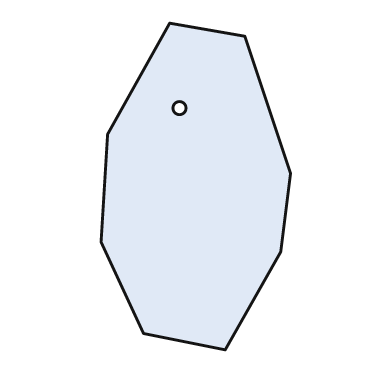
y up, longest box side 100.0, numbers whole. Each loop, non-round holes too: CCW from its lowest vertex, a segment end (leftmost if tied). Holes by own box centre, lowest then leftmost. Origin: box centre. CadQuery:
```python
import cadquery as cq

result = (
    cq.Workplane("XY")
    .moveTo(9.0, -50.0)
    .lineTo(26.0, -20.0)
    .lineTo(29.0, 4.0)
    .lineTo(15.0, 46.0)
    .lineTo(-8.0, 50.0)
    .lineTo(-27.0, 16.0)
    .lineTo(-29.0, -17.0)
    .lineTo(-16.0, -45.0)
    .close()
    .moveTo(-5.0, 24.0)
    .circle(2.0)
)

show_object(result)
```